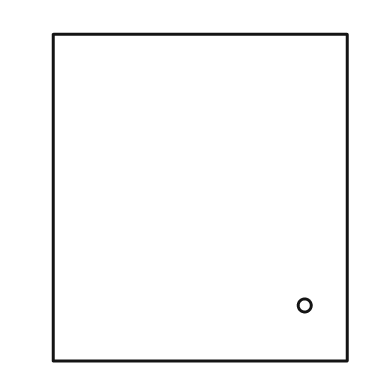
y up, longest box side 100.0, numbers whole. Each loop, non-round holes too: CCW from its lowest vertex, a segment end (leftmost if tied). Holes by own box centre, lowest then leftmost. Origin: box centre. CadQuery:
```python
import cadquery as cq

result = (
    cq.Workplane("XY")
    .moveTo(-45.0, -50.0)
    .lineTo(45.0, -50.0)
    .lineTo(45.0, 50.0)
    .lineTo(-45.0, 50.0)
    .close()
    .moveTo(32.0, -33.0)
    .circle(2.0)
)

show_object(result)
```